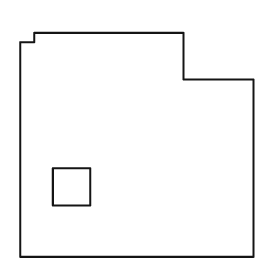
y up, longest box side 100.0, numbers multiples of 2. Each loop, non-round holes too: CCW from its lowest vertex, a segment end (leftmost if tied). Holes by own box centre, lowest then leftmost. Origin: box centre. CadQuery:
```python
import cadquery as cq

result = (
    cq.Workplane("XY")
    .moveTo(-50.0, -48.0)
    .lineTo(50.0, -48.0)
    .lineTo(50.0, 28.0)
    .lineTo(20.0, 28.0)
    .lineTo(20.0, 48.0)
    .lineTo(-44.0, 48.0)
    .lineTo(-44.0, 44.0)
    .lineTo(-50.0, 44.0)
    .close()
    .moveTo(-36.0, -26.0)
    .lineTo(-20.0, -26.0)
    .lineTo(-20.0, -10.0)
    .lineTo(-36.0, -10.0)
    .close()
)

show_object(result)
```